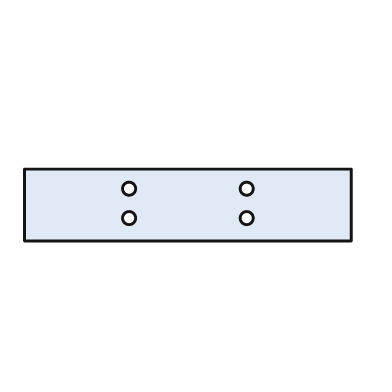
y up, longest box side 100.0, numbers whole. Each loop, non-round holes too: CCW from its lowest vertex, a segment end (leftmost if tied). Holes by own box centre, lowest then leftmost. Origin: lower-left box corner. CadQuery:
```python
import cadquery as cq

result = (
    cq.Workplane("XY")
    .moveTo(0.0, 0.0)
    .lineTo(100.0, 0.0)
    .lineTo(100.0, 22.0)
    .lineTo(0.0, 22.0)
    .close()
    .moveTo(32.0, 7.0)
    .circle(2.0)
    .moveTo(68.0, 7.0)
    .circle(2.0)
    .moveTo(32.0, 16.0)
    .circle(2.0)
    .moveTo(68.0, 16.0)
    .circle(2.0)
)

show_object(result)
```